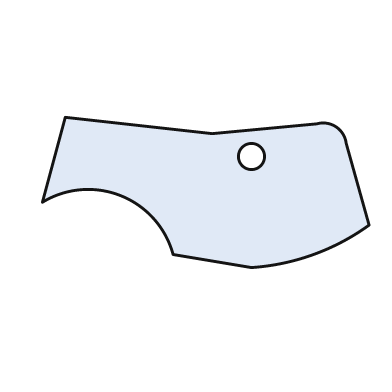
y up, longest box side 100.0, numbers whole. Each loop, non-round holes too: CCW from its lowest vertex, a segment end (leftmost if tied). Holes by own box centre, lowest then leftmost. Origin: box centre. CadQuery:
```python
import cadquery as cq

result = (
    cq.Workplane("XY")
    .moveTo(14.0, -23.0)
    .threePointArc((33.0, -19.0), (50.0, -10.0))
    .lineTo(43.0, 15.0)
    .threePointArc((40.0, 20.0), (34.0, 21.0))
    .lineTo(2.0, 18.0)
    .lineTo(-43.0, 23.0)
    .lineTo(-50.0, -3.0)
    .threePointArc((-26.0, -1.0), (-10.0, -19.0))
    .close()
    .moveTo(14.0, 11.0)
    .circle(4.0)
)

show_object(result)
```